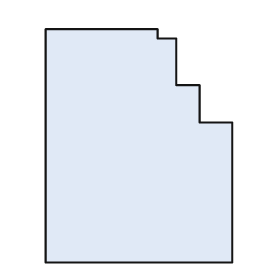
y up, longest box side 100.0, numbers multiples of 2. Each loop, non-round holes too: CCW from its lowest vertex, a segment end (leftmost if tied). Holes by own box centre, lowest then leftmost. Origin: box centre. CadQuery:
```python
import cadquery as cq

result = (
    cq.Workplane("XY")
    .moveTo(-40.0, -50.0)
    .lineTo(40.0, -50.0)
    .lineTo(40.0, 10.0)
    .lineTo(26.0, 10.0)
    .lineTo(26.0, 26.0)
    .lineTo(16.0, 26.0)
    .lineTo(16.0, 46.0)
    .lineTo(8.0, 46.0)
    .lineTo(8.0, 50.0)
    .lineTo(-40.0, 50.0)
    .close()
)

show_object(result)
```